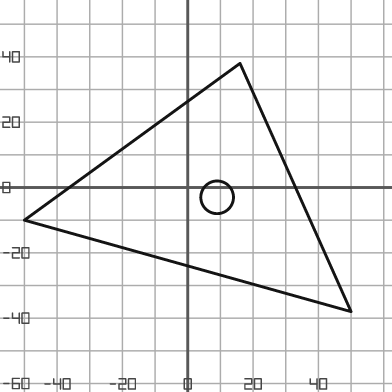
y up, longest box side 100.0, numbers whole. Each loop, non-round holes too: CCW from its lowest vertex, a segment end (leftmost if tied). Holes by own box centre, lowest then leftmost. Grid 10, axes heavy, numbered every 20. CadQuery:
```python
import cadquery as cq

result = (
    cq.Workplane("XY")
    .moveTo(50.0, -38.0)
    .lineTo(16.0, 38.0)
    .lineTo(-50.0, -10.0)
    .close()
    .moveTo(9.0, -3.0)
    .circle(5.0)
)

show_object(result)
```